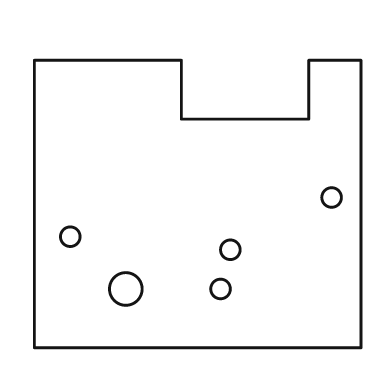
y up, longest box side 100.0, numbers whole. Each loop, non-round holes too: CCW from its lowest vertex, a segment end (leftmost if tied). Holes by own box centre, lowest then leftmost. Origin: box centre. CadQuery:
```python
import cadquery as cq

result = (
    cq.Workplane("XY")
    .moveTo(-50.0, -44.0)
    .lineTo(50.0, -44.0)
    .lineTo(50.0, 44.0)
    .lineTo(34.0, 44.0)
    .lineTo(34.0, 26.0)
    .lineTo(-5.0, 26.0)
    .lineTo(-5.0, 44.0)
    .lineTo(-50.0, 44.0)
    .close()
    .moveTo(-22.0, -26.0)
    .circle(5.0)
    .moveTo(7.0, -26.0)
    .circle(3.0)
    .moveTo(10.0, -14.0)
    .circle(3.0)
    .moveTo(-39.0, -10.0)
    .circle(3.0)
    .moveTo(41.0, 2.0)
    .circle(3.0)
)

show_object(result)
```